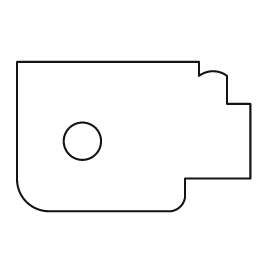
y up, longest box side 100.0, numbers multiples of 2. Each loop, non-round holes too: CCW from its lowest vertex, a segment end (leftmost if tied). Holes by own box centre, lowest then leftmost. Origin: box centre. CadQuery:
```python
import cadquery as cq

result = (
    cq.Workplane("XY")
    .moveTo(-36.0, -32.0)
    .lineTo(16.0, -32.0)
    .threePointArc((20.0, -30.0), (22.0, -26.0))
    .lineTo(22.0, -18.0)
    .lineTo(50.0, -18.0)
    .lineTo(50.0, 14.0)
    .lineTo(40.0, 14.0)
    .lineTo(40.0, 26.0)
    .threePointArc((34.0, 28.0), (28.0, 26.0))
    .lineTo(28.0, 32.0)
    .lineTo(-50.0, 32.0)
    .lineTo(-50.0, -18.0)
    .threePointArc((-46.0, -28.0), (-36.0, -32.0))
    .close()
    .moveTo(-22.0, -2.0)
    .circle(8.0)
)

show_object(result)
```